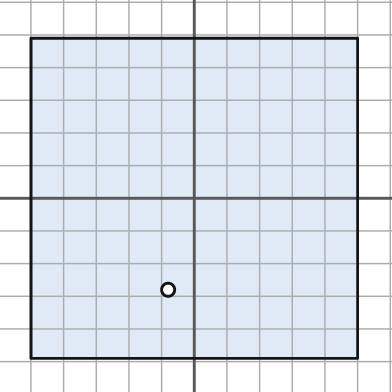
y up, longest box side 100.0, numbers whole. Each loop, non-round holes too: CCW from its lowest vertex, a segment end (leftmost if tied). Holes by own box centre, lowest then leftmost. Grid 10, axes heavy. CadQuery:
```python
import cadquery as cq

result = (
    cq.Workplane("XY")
    .moveTo(-50.0, -49.0)
    .lineTo(50.0, -49.0)
    .lineTo(50.0, 49.0)
    .lineTo(-50.0, 49.0)
    .close()
    .moveTo(-8.0, -28.0)
    .circle(2.0)
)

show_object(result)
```